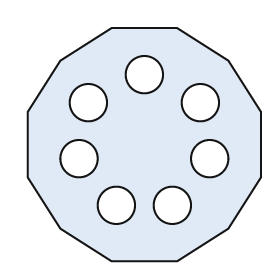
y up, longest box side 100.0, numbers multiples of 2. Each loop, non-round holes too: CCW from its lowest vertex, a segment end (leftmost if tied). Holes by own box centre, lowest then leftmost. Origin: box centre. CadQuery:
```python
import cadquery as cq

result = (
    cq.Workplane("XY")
    .moveTo(-14.0, -50.0)
    .lineTo(14.0, -50.0)
    .lineTo(36.0, -36.0)
    .lineTo(50.0, -14.0)
    .lineTo(50.0, 14.0)
    .lineTo(36.0, 36.0)
    .lineTo(14.0, 50.0)
    .lineTo(-14.0, 50.0)
    .lineTo(-36.0, 36.0)
    .lineTo(-50.0, 14.0)
    .lineTo(-50.0, -14.0)
    .lineTo(-36.0, -36.0)
    .close()
    .moveTo(-12.0, -26.0)
    .circle(8.0)
    .moveTo(12.0, -26.0)
    .circle(8.0)
    .moveTo(-28.0, -6.0)
    .circle(8.0)
    .moveTo(28.0, -6.0)
    .circle(8.0)
    .moveTo(-24.0, 18.0)
    .circle(8.0)
    .moveTo(24.0, 18.0)
    .circle(8.0)
    .moveTo(0.0, 30.0)
    .circle(8.0)
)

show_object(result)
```